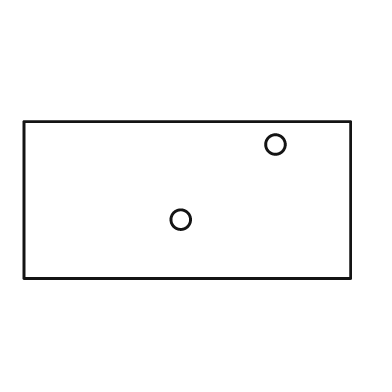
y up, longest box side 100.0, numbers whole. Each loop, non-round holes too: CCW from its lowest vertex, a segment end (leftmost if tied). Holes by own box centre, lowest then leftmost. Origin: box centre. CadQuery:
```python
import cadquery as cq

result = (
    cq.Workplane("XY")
    .moveTo(-50.0, -24.0)
    .lineTo(50.0, -24.0)
    .lineTo(50.0, 24.0)
    .lineTo(-50.0, 24.0)
    .close()
    .moveTo(-2.0, -6.0)
    .circle(3.0)
    .moveTo(27.0, 17.0)
    .circle(3.0)
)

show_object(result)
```